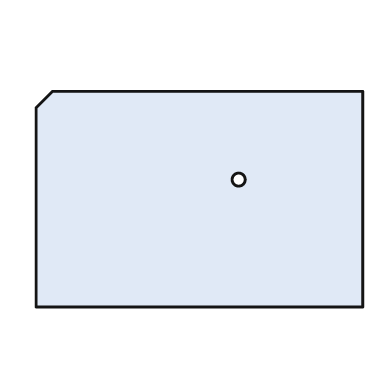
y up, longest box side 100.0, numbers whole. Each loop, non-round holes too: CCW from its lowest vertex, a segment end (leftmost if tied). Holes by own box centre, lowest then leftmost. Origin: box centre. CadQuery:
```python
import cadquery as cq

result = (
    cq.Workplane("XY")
    .moveTo(-50.0, -33.0)
    .lineTo(50.0, -33.0)
    .lineTo(50.0, 33.0)
    .lineTo(-45.0, 33.0)
    .lineTo(-50.0, 28.0)
    .close()
    .moveTo(12.0, 6.0)
    .circle(2.0)
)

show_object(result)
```